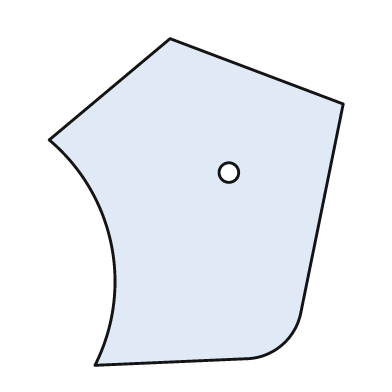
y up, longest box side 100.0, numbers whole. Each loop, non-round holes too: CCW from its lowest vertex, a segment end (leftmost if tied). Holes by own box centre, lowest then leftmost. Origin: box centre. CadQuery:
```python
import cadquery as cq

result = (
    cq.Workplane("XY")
    .moveTo(-31.0, -50.0)
    .lineTo(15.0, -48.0)
    .threePointArc((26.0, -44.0), (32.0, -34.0))
    .lineTo(45.0, 30.0)
    .lineTo(-8.0, 50.0)
    .lineTo(-45.0, 19.0)
    .threePointArc((-26.0, -13.0), (-31.0, -50.0))
    .close()
    .moveTo(10.0, 9.0)
    .circle(3.0)
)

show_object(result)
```